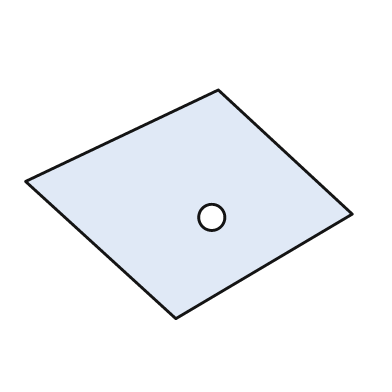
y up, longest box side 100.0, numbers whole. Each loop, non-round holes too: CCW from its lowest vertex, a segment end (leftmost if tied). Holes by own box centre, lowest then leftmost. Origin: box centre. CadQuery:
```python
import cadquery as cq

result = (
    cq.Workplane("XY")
    .moveTo(-4.0, -35.0)
    .lineTo(50.0, -3.0)
    .lineTo(9.0, 35.0)
    .lineTo(-50.0, 7.0)
    .close()
    .moveTo(7.0, -4.0)
    .circle(4.0)
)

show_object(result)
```